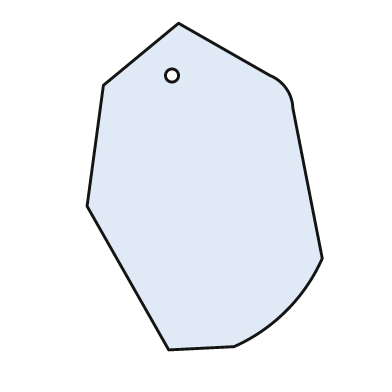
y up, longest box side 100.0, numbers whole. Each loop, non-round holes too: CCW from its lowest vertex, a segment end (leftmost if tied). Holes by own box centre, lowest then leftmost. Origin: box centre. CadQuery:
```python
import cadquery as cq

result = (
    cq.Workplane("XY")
    .moveTo(-11.0, -50.0)
    .lineTo(9.0, -49.0)
    .threePointArc((25.0, -38.0), (36.0, -22.0))
    .lineTo(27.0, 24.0)
    .threePointArc((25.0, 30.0), (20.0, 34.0))
    .lineTo(-8.0, 50.0)
    .lineTo(-31.0, 31.0)
    .lineTo(-36.0, -6.0)
    .close()
    .moveTo(-10.0, 34.0)
    .circle(2.0)
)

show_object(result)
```